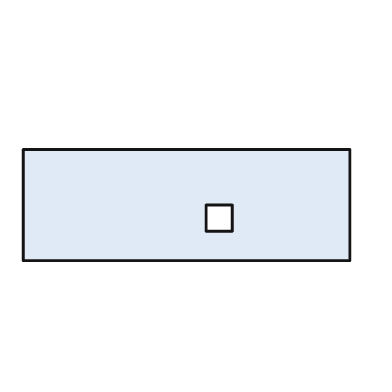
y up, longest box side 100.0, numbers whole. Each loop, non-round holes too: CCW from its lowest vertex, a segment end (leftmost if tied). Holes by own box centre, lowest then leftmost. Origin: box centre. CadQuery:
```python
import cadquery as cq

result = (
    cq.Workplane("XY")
    .moveTo(-50.0, -17.0)
    .lineTo(50.0, -17.0)
    .lineTo(50.0, 17.0)
    .lineTo(-50.0, 17.0)
    .close()
    .moveTo(6.0, -8.0)
    .lineTo(14.0, -8.0)
    .lineTo(14.0, 0.0)
    .lineTo(6.0, 0.0)
    .close()
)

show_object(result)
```